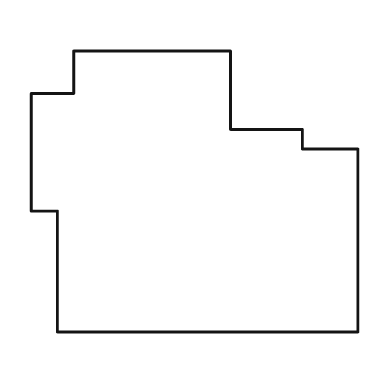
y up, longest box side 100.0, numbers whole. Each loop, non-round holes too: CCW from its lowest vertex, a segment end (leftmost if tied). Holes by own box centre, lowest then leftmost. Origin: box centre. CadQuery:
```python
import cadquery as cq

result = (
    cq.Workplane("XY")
    .moveTo(-42.0, -43.0)
    .lineTo(50.0, -43.0)
    .lineTo(50.0, 13.0)
    .lineTo(33.0, 13.0)
    .lineTo(33.0, 19.0)
    .lineTo(11.0, 19.0)
    .lineTo(11.0, 43.0)
    .lineTo(-37.0, 43.0)
    .lineTo(-37.0, 30.0)
    .lineTo(-50.0, 30.0)
    .lineTo(-50.0, -6.0)
    .lineTo(-42.0, -6.0)
    .close()
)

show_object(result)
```